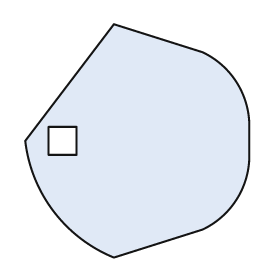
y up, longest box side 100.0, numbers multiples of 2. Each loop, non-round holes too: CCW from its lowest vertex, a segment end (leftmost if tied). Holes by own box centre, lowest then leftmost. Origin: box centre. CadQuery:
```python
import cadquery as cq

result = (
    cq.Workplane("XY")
    .moveTo(-10.0, -50.0)
    .lineTo(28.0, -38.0)
    .threePointArc((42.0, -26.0), (48.0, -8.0))
    .lineTo(48.0, 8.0)
    .threePointArc((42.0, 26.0), (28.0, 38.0))
    .lineTo(-10.0, 50.0)
    .lineTo(-48.0, 0.0)
    .threePointArc((-36.0, -30.0), (-10.0, -50.0))
    .close()
    .moveTo(-38.0, -6.0)
    .lineTo(-26.0, -6.0)
    .lineTo(-26.0, 6.0)
    .lineTo(-38.0, 6.0)
    .close()
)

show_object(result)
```